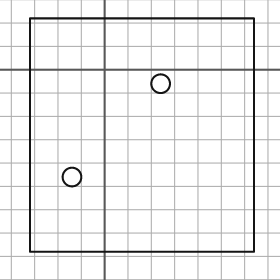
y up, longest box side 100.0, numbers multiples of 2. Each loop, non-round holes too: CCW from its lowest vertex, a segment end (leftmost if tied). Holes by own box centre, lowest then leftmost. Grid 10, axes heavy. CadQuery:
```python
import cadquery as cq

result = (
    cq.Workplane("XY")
    .moveTo(-32.0, -78.0)
    .lineTo(64.0, -78.0)
    .lineTo(64.0, 22.0)
    .lineTo(-32.0, 22.0)
    .close()
    .moveTo(-14.0, -46.0)
    .circle(4.0)
    .moveTo(24.0, -6.0)
    .circle(4.0)
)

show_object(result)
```